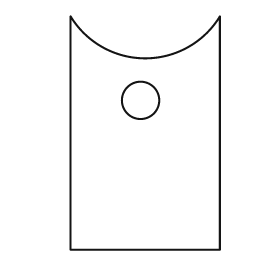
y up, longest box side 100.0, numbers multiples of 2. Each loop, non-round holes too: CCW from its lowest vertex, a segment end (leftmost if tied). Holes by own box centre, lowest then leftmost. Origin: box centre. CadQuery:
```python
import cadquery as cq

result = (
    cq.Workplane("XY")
    .moveTo(-32.0, -50.0)
    .lineTo(32.0, -50.0)
    .lineTo(32.0, 50.0)
    .threePointArc((0.0, 32.0), (-32.0, 50.0))
    .close()
    .moveTo(-2.0, 14.0)
    .circle(8.0)
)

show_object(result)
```